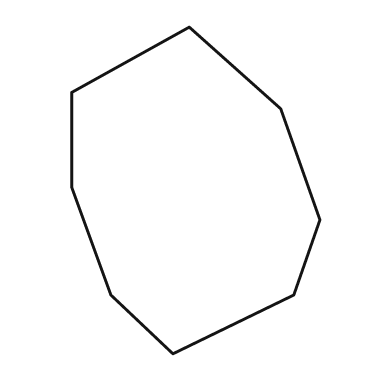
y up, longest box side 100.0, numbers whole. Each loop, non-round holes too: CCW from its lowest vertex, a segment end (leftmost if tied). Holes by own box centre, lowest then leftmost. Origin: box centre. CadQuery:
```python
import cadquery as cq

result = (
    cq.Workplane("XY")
    .moveTo(-7.0, -50.0)
    .lineTo(30.0, -32.0)
    .lineTo(38.0, -9.0)
    .lineTo(26.0, 25.0)
    .lineTo(-2.0, 50.0)
    .lineTo(-38.0, 30.0)
    .lineTo(-38.0, 1.0)
    .lineTo(-26.0, -32.0)
    .close()
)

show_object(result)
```